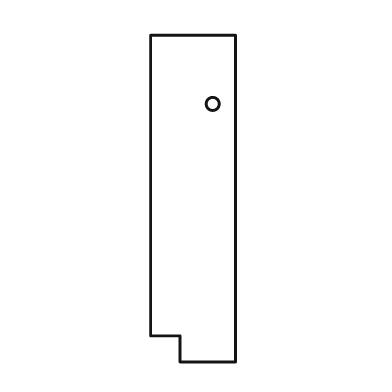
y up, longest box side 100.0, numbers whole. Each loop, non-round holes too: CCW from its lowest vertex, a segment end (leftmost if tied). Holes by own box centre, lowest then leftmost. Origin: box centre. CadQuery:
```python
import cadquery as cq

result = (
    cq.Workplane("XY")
    .moveTo(-4.0, -50.0)
    .lineTo(13.0, -50.0)
    .lineTo(13.0, 50.0)
    .lineTo(-13.0, 50.0)
    .lineTo(-13.0, -42.0)
    .lineTo(-4.0, -42.0)
    .close()
    .moveTo(6.0, 29.0)
    .circle(2.0)
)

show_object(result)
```